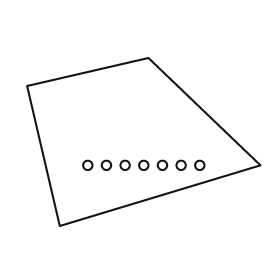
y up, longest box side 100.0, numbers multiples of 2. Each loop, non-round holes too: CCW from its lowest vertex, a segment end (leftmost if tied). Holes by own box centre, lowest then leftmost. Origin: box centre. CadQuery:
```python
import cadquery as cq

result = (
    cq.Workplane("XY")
    .moveTo(-36.0, -36.0)
    .lineTo(50.0, -10.0)
    .lineTo(2.0, 36.0)
    .lineTo(-50.0, 24.0)
    .close()
    .moveTo(-24.0, -10.0)
    .circle(2.0)
    .moveTo(-16.0, -10.0)
    .circle(2.0)
    .moveTo(-8.0, -10.0)
    .circle(2.0)
    .moveTo(0.0, -10.0)
    .circle(2.0)
    .moveTo(8.0, -10.0)
    .circle(2.0)
    .moveTo(16.0, -10.0)
    .circle(2.0)
    .moveTo(24.0, -10.0)
    .circle(2.0)
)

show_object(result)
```